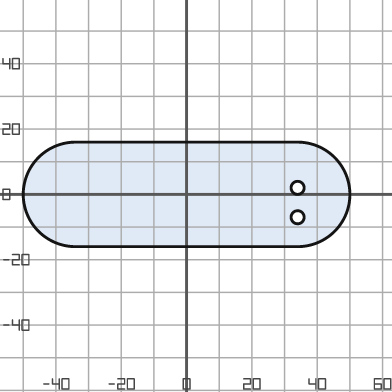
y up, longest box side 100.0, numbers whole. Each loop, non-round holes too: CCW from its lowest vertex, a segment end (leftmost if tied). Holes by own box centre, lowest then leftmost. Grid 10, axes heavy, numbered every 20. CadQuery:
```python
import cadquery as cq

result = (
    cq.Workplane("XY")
    .moveTo(-34.0, -16.0)
    .lineTo(34.0, -16.0)
    .threePointArc((50.0, 0.0), (34.0, 16.0))
    .lineTo(-34.0, 16.0)
    .threePointArc((-50.0, 0.0), (-34.0, -16.0))
    .close()
    .moveTo(34.0, -7.0)
    .circle(2.0)
    .moveTo(34.0, 2.0)
    .circle(2.0)
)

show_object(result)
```